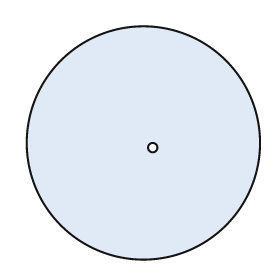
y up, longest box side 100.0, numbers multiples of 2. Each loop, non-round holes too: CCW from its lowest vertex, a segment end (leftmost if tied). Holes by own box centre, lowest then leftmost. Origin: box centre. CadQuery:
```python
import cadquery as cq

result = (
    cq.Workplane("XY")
    .moveTo(0.0, 0.0)
    .circle(50.0)
    .moveTo(4.0, -2.0)
    .circle(2.0)
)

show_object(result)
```